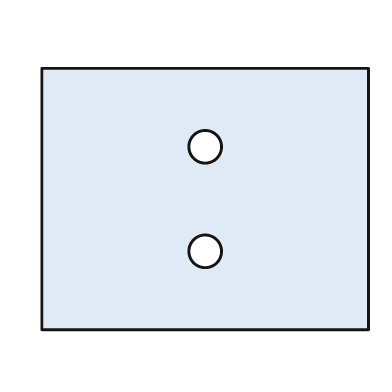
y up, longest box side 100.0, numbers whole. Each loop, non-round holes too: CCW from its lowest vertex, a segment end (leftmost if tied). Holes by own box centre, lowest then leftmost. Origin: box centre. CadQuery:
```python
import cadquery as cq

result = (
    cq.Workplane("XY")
    .moveTo(-50.0, -40.0)
    .lineTo(50.0, -40.0)
    .lineTo(50.0, 40.0)
    .lineTo(-50.0, 40.0)
    .close()
    .moveTo(0.0, -16.0)
    .circle(5.0)
    .moveTo(0.0, 16.0)
    .circle(5.0)
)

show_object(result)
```